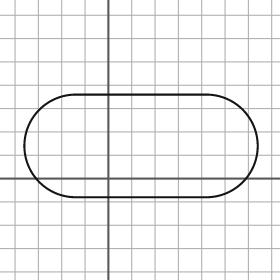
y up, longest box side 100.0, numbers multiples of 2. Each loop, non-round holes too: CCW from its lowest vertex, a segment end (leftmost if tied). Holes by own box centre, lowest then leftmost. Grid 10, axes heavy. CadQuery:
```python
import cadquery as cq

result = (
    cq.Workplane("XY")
    .moveTo(-14.0, -8.0)
    .lineTo(42.0, -8.0)
    .threePointArc((64.0, 14.0), (42.0, 36.0))
    .lineTo(-14.0, 36.0)
    .threePointArc((-36.0, 14.0), (-14.0, -8.0))
    .close()
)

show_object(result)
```